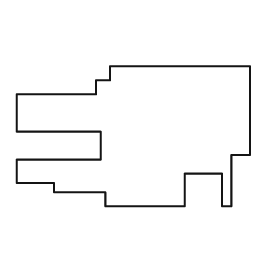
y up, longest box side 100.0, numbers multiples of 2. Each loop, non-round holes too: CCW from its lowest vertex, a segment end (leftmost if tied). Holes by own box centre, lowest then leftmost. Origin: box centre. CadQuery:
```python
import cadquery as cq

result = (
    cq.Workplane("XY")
    .moveTo(-12.0, -30.0)
    .lineTo(22.0, -30.0)
    .lineTo(22.0, -16.0)
    .lineTo(38.0, -16.0)
    .lineTo(38.0, -30.0)
    .lineTo(42.0, -30.0)
    .lineTo(42.0, -8.0)
    .lineTo(50.0, -8.0)
    .lineTo(50.0, 30.0)
    .lineTo(-10.0, 30.0)
    .lineTo(-10.0, 24.0)
    .lineTo(-16.0, 24.0)
    .lineTo(-16.0, 18.0)
    .lineTo(-50.0, 18.0)
    .lineTo(-50.0, 2.0)
    .lineTo(-14.0, 2.0)
    .lineTo(-14.0, -10.0)
    .lineTo(-50.0, -10.0)
    .lineTo(-50.0, -20.0)
    .lineTo(-34.0, -20.0)
    .lineTo(-34.0, -24.0)
    .lineTo(-12.0, -24.0)
    .close()
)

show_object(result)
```